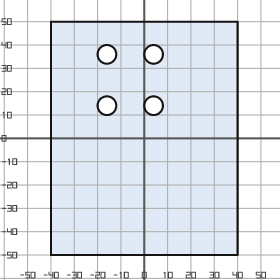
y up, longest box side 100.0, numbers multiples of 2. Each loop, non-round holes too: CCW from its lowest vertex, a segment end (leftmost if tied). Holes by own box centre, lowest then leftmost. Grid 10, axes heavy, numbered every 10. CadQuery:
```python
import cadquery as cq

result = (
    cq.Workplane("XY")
    .moveTo(-40.0, -50.0)
    .lineTo(40.0, -50.0)
    .lineTo(40.0, 50.0)
    .lineTo(-40.0, 50.0)
    .close()
    .moveTo(-16.0, 14.0)
    .circle(4.0)
    .moveTo(4.0, 14.0)
    .circle(4.0)
    .moveTo(-16.0, 36.0)
    .circle(4.0)
    .moveTo(4.0, 36.0)
    .circle(4.0)
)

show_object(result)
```